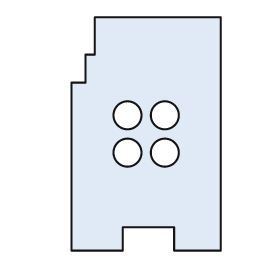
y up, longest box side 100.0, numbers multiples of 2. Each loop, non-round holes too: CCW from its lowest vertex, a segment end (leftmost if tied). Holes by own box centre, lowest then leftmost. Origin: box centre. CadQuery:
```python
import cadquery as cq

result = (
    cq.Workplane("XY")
    .moveTo(-32.0, -50.0)
    .lineTo(-10.0, -50.0)
    .lineTo(-10.0, -40.0)
    .lineTo(12.0, -40.0)
    .lineTo(12.0, -50.0)
    .lineTo(32.0, -50.0)
    .lineTo(32.0, 50.0)
    .lineTo(-22.0, 50.0)
    .lineTo(-22.0, 34.0)
    .lineTo(-26.0, 34.0)
    .lineTo(-26.0, 22.0)
    .lineTo(-32.0, 22.0)
    .close()
    .moveTo(-8.0, -8.0)
    .circle(6.0)
    .moveTo(8.0, -8.0)
    .circle(6.0)
    .moveTo(-8.0, 8.0)
    .circle(6.0)
    .moveTo(8.0, 8.0)
    .circle(6.0)
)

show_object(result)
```